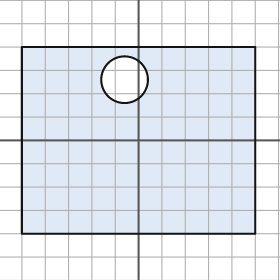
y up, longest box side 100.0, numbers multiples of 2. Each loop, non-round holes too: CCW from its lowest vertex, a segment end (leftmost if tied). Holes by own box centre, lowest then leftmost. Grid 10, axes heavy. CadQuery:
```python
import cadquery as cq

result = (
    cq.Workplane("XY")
    .moveTo(-50.0, -40.0)
    .lineTo(50.0, -40.0)
    .lineTo(50.0, 40.0)
    .lineTo(-50.0, 40.0)
    .close()
    .moveTo(-6.0, 26.0)
    .circle(10.0)
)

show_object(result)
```